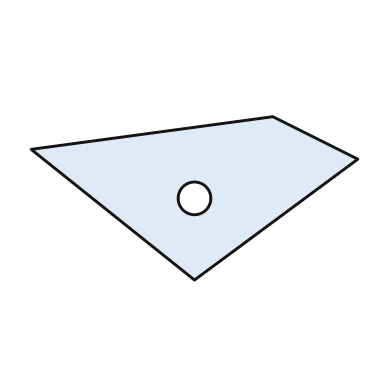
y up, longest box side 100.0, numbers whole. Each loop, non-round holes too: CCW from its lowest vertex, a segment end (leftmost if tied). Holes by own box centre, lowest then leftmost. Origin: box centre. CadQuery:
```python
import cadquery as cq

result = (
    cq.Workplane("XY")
    .moveTo(0.0, -25.0)
    .lineTo(50.0, 12.0)
    .lineTo(24.0, 25.0)
    .lineTo(-50.0, 15.0)
    .close()
    .moveTo(0.0, 0.0)
    .circle(5.0)
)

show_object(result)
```